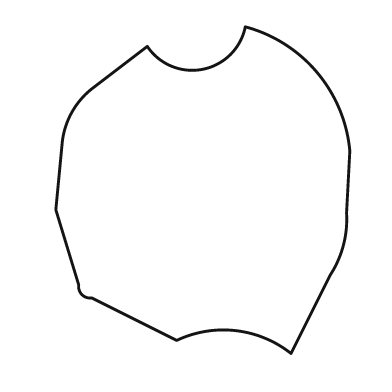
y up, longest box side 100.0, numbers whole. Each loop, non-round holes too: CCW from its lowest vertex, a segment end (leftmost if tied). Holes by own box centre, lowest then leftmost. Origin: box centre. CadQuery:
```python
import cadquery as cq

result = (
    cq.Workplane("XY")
    .moveTo(27.0, -50.0)
    .lineTo(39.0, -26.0)
    .threePointArc((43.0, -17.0), (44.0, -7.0))
    .lineTo(45.0, 12.0)
    .threePointArc((35.0, 36.0), (13.0, 50.0))
    .threePointArc((0.0, 37.0), (-17.0, 44.0))
    .lineTo(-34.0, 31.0)
    .threePointArc((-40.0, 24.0), (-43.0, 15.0))
    .lineTo(-45.0, -6.0)
    .lineTo(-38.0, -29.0)
    .threePointArc((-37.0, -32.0), (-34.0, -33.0))
    .lineTo(-8.0, -46.0)
    .threePointArc((10.0, -43.0), (27.0, -50.0))
    .close()
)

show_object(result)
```